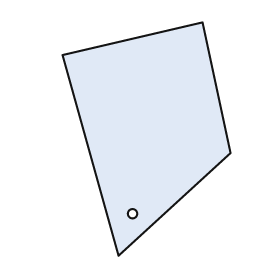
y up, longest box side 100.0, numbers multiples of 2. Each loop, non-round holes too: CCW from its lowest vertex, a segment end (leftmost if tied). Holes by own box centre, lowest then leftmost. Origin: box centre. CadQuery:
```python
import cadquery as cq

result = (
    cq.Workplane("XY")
    .moveTo(-12.0, -50.0)
    .lineTo(36.0, -6.0)
    .lineTo(24.0, 50.0)
    .lineTo(-36.0, 36.0)
    .close()
    .moveTo(-6.0, -32.0)
    .circle(2.0)
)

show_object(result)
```